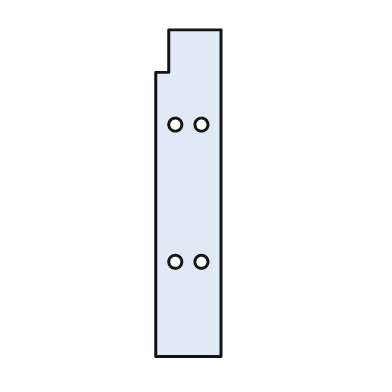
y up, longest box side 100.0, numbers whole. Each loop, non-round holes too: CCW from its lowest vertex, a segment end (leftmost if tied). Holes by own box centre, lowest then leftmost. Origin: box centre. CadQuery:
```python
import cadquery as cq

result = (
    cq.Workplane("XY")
    .moveTo(-10.0, -50.0)
    .lineTo(10.0, -50.0)
    .lineTo(10.0, 50.0)
    .lineTo(-6.0, 50.0)
    .lineTo(-6.0, 37.0)
    .lineTo(-10.0, 37.0)
    .close()
    .moveTo(-4.0, -21.0)
    .circle(2.0)
    .moveTo(4.0, -21.0)
    .circle(2.0)
    .moveTo(-4.0, 21.0)
    .circle(2.0)
    .moveTo(4.0, 21.0)
    .circle(2.0)
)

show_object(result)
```